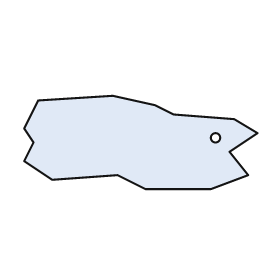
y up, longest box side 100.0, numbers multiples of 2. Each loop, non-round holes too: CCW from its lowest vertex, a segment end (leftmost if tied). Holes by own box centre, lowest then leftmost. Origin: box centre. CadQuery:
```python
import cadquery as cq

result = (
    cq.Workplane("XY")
    .moveTo(2.0, -20.0)
    .lineTo(30.0, -20.0)
    .lineTo(46.0, -14.0)
    .lineTo(38.0, -4.0)
    .lineTo(50.0, 4.0)
    .lineTo(40.0, 10.0)
    .lineTo(14.0, 12.0)
    .lineTo(6.0, 16.0)
    .lineTo(-12.0, 20.0)
    .lineTo(-44.0, 18.0)
    .lineTo(-50.0, 6.0)
    .lineTo(-46.0, 0.0)
    .lineTo(-50.0, -8.0)
    .lineTo(-38.0, -16.0)
    .lineTo(-10.0, -14.0)
    .close()
    .moveTo(32.0, 2.0)
    .circle(2.0)
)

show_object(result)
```